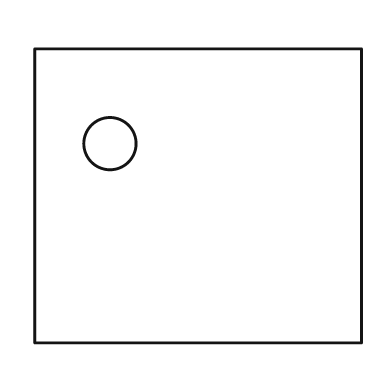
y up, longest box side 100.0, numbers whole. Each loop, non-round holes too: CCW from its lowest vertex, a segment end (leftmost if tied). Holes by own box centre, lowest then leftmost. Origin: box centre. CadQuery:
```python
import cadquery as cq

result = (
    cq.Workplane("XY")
    .moveTo(-50.0, -45.0)
    .lineTo(50.0, -45.0)
    .lineTo(50.0, 45.0)
    .lineTo(-50.0, 45.0)
    .close()
    .moveTo(-27.0, 16.0)
    .circle(8.0)
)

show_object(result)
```